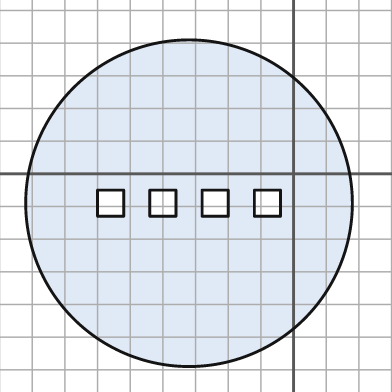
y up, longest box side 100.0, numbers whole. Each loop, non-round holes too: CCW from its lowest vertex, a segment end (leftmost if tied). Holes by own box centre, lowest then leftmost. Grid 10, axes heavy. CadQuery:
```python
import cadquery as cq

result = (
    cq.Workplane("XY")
    .moveTo(-32.0, -9.0)
    .circle(50.0)
    .moveTo(-60.0, -13.0)
    .lineTo(-52.0, -13.0)
    .lineTo(-52.0, -5.0)
    .lineTo(-60.0, -5.0)
    .close()
    .moveTo(-44.0, -13.0)
    .lineTo(-36.0, -13.0)
    .lineTo(-36.0, -5.0)
    .lineTo(-44.0, -5.0)
    .close()
    .moveTo(-28.0, -13.0)
    .lineTo(-20.0, -13.0)
    .lineTo(-20.0, -5.0)
    .lineTo(-28.0, -5.0)
    .close()
    .moveTo(-12.0, -13.0)
    .lineTo(-4.0, -13.0)
    .lineTo(-4.0, -5.0)
    .lineTo(-12.0, -5.0)
    .close()
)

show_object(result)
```